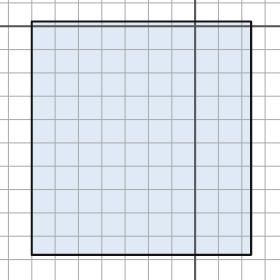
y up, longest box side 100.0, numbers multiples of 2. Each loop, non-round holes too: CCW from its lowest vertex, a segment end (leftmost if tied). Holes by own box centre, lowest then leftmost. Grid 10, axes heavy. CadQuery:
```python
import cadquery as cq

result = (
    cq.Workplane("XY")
    .moveTo(-70.0, -98.0)
    .lineTo(24.0, -98.0)
    .lineTo(24.0, 2.0)
    .lineTo(-70.0, 2.0)
    .close()
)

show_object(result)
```